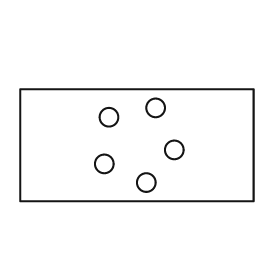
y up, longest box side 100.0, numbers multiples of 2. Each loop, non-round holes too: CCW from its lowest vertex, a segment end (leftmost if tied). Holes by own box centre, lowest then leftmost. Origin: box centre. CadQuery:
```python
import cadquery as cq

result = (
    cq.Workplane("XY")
    .moveTo(-50.0, -24.0)
    .lineTo(50.0, -24.0)
    .lineTo(50.0, 24.0)
    .lineTo(-50.0, 24.0)
    .close()
    .moveTo(4.0, -16.0)
    .circle(4.0)
    .moveTo(-14.0, -8.0)
    .circle(4.0)
    .moveTo(16.0, -2.0)
    .circle(4.0)
    .moveTo(-12.0, 12.0)
    .circle(4.0)
    .moveTo(8.0, 16.0)
    .circle(4.0)
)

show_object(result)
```